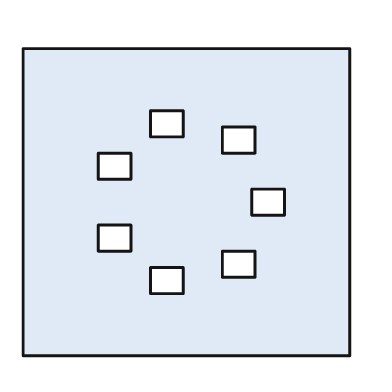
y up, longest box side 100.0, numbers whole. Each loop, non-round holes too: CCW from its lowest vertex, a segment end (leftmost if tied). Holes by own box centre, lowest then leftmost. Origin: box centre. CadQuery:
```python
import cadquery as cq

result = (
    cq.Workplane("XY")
    .moveTo(-50.0, -47.0)
    .lineTo(50.0, -47.0)
    .lineTo(50.0, 47.0)
    .lineTo(-50.0, 47.0)
    .close()
    .moveTo(-11.0, -28.0)
    .lineTo(-1.0, -28.0)
    .lineTo(-1.0, -20.0)
    .lineTo(-11.0, -20.0)
    .close()
    .moveTo(11.0, -23.0)
    .lineTo(21.0, -23.0)
    .lineTo(21.0, -15.0)
    .lineTo(11.0, -15.0)
    .close()
    .moveTo(-27.0, -15.0)
    .lineTo(-17.0, -15.0)
    .lineTo(-17.0, -7.0)
    .lineTo(-27.0, -7.0)
    .close()
    .moveTo(20.0, -4.0)
    .lineTo(30.0, -4.0)
    .lineTo(30.0, 4.0)
    .lineTo(20.0, 4.0)
    .close()
    .moveTo(-27.0, 7.0)
    .lineTo(-17.0, 7.0)
    .lineTo(-17.0, 15.0)
    .lineTo(-27.0, 15.0)
    .close()
    .moveTo(11.0, 15.0)
    .lineTo(21.0, 15.0)
    .lineTo(21.0, 23.0)
    .lineTo(11.0, 23.0)
    .close()
    .moveTo(-11.0, 20.0)
    .lineTo(-1.0, 20.0)
    .lineTo(-1.0, 28.0)
    .lineTo(-11.0, 28.0)
    .close()
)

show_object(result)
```